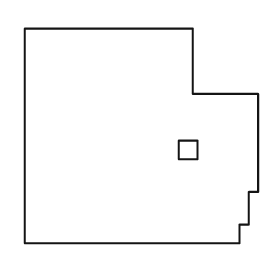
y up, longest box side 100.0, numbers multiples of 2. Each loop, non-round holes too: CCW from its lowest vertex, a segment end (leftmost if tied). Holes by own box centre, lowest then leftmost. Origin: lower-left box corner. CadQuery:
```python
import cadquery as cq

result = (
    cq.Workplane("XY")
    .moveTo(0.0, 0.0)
    .lineTo(92.0, 0.0)
    .lineTo(92.0, 8.0)
    .lineTo(96.0, 8.0)
    .lineTo(96.0, 22.0)
    .lineTo(100.0, 22.0)
    .lineTo(100.0, 64.0)
    .lineTo(72.0, 64.0)
    .lineTo(72.0, 92.0)
    .lineTo(0.0, 92.0)
    .close()
    .moveTo(66.0, 36.0)
    .lineTo(74.0, 36.0)
    .lineTo(74.0, 44.0)
    .lineTo(66.0, 44.0)
    .close()
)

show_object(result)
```